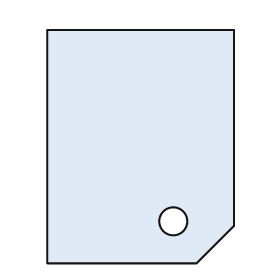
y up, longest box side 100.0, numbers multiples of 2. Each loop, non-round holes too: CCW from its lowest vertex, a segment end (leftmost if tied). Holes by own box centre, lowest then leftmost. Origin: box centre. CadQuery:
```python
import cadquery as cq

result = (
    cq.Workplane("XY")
    .moveTo(-40.0, -50.0)
    .lineTo(24.0, -50.0)
    .lineTo(40.0, -34.0)
    .lineTo(40.0, 50.0)
    .lineTo(-40.0, 50.0)
    .close()
    .moveTo(14.0, -32.0)
    .circle(6.0)
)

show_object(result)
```